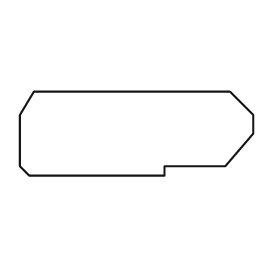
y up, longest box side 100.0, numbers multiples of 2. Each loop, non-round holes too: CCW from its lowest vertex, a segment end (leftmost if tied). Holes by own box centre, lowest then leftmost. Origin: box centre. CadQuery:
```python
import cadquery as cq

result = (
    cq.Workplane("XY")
    .moveTo(-46.0, -18.0)
    .lineTo(12.0, -18.0)
    .lineTo(12.0, -14.0)
    .lineTo(38.0, -14.0)
    .lineTo(50.0, 0.0)
    .lineTo(50.0, 8.0)
    .lineTo(40.0, 18.0)
    .lineTo(-44.0, 18.0)
    .lineTo(-50.0, 8.0)
    .lineTo(-50.0, -14.0)
    .close()
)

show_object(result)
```